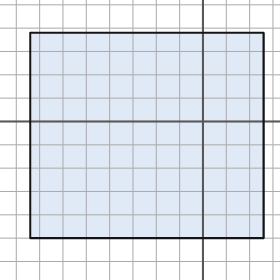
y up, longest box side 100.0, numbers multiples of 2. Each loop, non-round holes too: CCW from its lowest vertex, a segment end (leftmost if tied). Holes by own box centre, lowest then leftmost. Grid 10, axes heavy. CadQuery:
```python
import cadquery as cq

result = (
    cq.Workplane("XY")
    .moveTo(-74.0, -50.0)
    .lineTo(26.0, -50.0)
    .lineTo(26.0, 38.0)
    .lineTo(-74.0, 38.0)
    .close()
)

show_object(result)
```